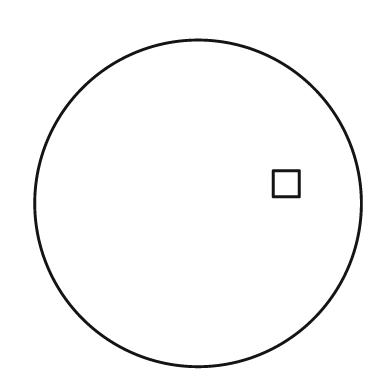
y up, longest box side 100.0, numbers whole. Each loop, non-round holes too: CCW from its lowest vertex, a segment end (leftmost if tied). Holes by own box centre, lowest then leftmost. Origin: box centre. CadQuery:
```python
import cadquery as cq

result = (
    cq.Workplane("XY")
    .moveTo(0.0, 0.0)
    .circle(50.0)
    .moveTo(23.0, 2.0)
    .lineTo(31.0, 2.0)
    .lineTo(31.0, 10.0)
    .lineTo(23.0, 10.0)
    .close()
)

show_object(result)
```